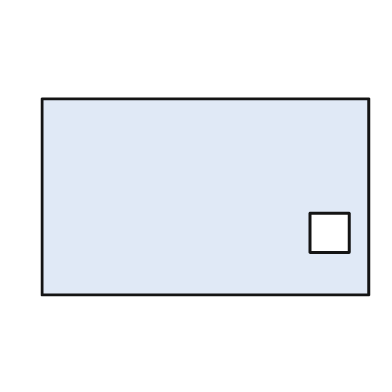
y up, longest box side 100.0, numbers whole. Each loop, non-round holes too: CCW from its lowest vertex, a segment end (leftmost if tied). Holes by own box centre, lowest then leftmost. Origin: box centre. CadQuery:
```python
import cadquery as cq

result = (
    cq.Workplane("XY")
    .moveTo(-50.0, -30.0)
    .lineTo(50.0, -30.0)
    .lineTo(50.0, 30.0)
    .lineTo(-50.0, 30.0)
    .close()
    .moveTo(32.0, -17.0)
    .lineTo(44.0, -17.0)
    .lineTo(44.0, -5.0)
    .lineTo(32.0, -5.0)
    .close()
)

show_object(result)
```